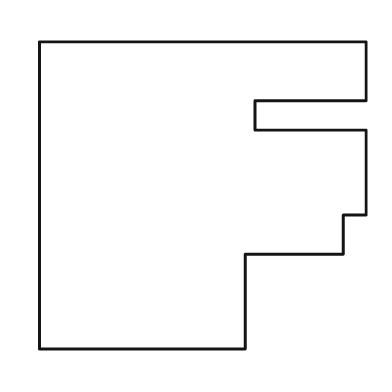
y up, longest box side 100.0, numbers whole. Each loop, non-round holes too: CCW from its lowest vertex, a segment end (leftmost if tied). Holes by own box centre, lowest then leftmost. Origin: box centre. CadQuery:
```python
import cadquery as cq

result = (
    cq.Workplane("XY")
    .moveTo(-50.0, -47.0)
    .lineTo(13.0, -47.0)
    .lineTo(13.0, -18.0)
    .lineTo(43.0, -18.0)
    .lineTo(43.0, -6.0)
    .lineTo(50.0, -6.0)
    .lineTo(50.0, 20.0)
    .lineTo(16.0, 20.0)
    .lineTo(16.0, 29.0)
    .lineTo(50.0, 29.0)
    .lineTo(50.0, 47.0)
    .lineTo(-50.0, 47.0)
    .close()
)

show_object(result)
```